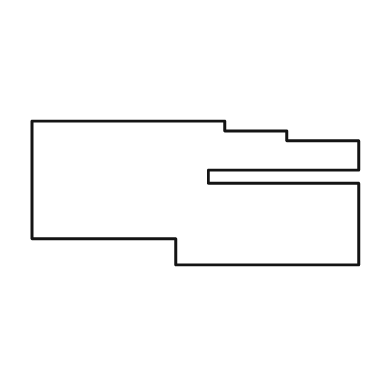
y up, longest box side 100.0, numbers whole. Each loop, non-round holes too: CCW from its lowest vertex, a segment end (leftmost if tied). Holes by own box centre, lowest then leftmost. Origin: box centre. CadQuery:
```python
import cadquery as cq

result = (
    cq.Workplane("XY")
    .moveTo(-6.0, -22.0)
    .lineTo(50.0, -22.0)
    .lineTo(50.0, 3.0)
    .lineTo(4.0, 3.0)
    .lineTo(4.0, 7.0)
    .lineTo(50.0, 7.0)
    .lineTo(50.0, 16.0)
    .lineTo(28.0, 16.0)
    .lineTo(28.0, 19.0)
    .lineTo(9.0, 19.0)
    .lineTo(9.0, 22.0)
    .lineTo(-50.0, 22.0)
    .lineTo(-50.0, -14.0)
    .lineTo(-6.0, -14.0)
    .close()
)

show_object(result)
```